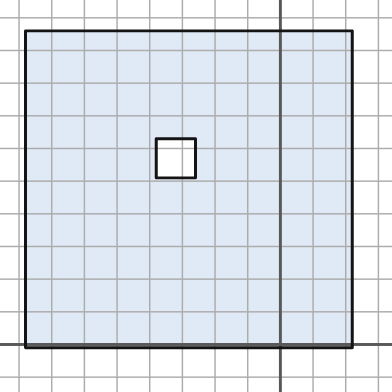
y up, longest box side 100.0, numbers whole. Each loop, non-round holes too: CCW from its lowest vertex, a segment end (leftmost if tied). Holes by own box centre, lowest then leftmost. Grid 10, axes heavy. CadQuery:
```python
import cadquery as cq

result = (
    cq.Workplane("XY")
    .moveTo(-78.0, -1.0)
    .lineTo(22.0, -1.0)
    .lineTo(22.0, 96.0)
    .lineTo(-78.0, 96.0)
    .close()
    .moveTo(-38.0, 51.0)
    .lineTo(-26.0, 51.0)
    .lineTo(-26.0, 63.0)
    .lineTo(-38.0, 63.0)
    .close()
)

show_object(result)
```